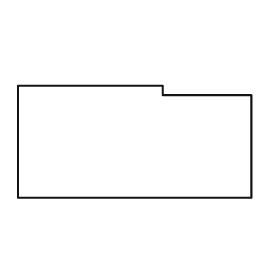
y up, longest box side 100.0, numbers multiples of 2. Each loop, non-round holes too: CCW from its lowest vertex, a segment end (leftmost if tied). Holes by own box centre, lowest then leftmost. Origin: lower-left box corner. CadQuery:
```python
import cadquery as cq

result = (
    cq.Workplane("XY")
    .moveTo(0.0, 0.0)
    .lineTo(100.0, 0.0)
    .lineTo(100.0, 44.0)
    .lineTo(62.0, 44.0)
    .lineTo(62.0, 48.0)
    .lineTo(0.0, 48.0)
    .close()
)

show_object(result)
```